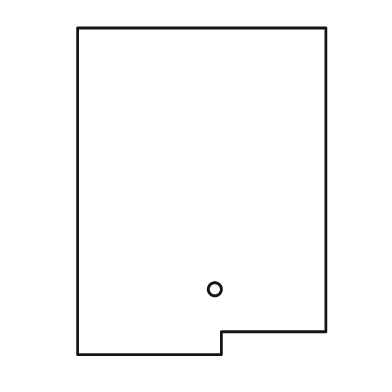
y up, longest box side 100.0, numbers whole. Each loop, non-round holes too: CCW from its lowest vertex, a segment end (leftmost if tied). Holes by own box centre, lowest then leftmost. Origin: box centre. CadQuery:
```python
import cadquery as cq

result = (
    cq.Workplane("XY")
    .moveTo(-38.0, -50.0)
    .lineTo(6.0, -50.0)
    .lineTo(6.0, -43.0)
    .lineTo(38.0, -43.0)
    .lineTo(38.0, 50.0)
    .lineTo(-38.0, 50.0)
    .close()
    .moveTo(4.0, -30.0)
    .circle(2.0)
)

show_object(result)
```